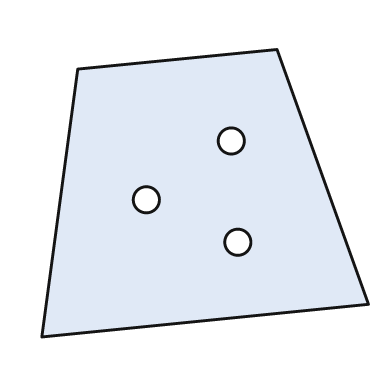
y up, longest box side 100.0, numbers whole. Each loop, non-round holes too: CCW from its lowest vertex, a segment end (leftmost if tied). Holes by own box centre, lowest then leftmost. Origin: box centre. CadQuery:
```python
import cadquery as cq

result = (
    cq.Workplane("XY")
    .moveTo(-50.0, -44.0)
    .lineTo(50.0, -34.0)
    .lineTo(22.0, 44.0)
    .lineTo(-39.0, 38.0)
    .close()
    .moveTo(10.0, -15.0)
    .circle(4.0)
    .moveTo(-18.0, -2.0)
    .circle(4.0)
    .moveTo(8.0, 16.0)
    .circle(4.0)
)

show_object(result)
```